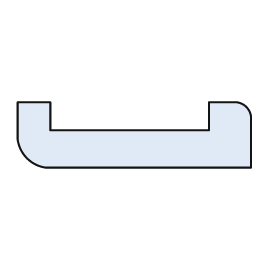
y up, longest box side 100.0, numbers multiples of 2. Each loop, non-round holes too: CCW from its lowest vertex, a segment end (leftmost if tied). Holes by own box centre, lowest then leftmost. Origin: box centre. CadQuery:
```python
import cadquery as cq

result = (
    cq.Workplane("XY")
    .moveTo(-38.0, -14.0)
    .lineTo(50.0, -14.0)
    .lineTo(50.0, 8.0)
    .threePointArc((48.0, 12.0), (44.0, 14.0))
    .lineTo(32.0, 14.0)
    .lineTo(32.0, 2.0)
    .lineTo(-36.0, 2.0)
    .lineTo(-36.0, 14.0)
    .lineTo(-50.0, 14.0)
    .lineTo(-50.0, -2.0)
    .threePointArc((-46.0, -10.0), (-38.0, -14.0))
    .close()
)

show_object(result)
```